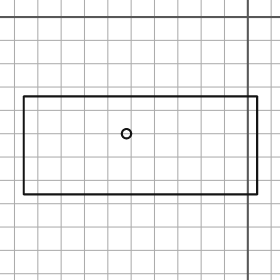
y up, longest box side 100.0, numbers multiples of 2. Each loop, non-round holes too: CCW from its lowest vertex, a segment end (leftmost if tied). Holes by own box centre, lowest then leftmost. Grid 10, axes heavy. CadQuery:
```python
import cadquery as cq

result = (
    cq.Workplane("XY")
    .moveTo(-96.0, -76.0)
    .lineTo(4.0, -76.0)
    .lineTo(4.0, -34.0)
    .lineTo(-96.0, -34.0)
    .close()
    .moveTo(-52.0, -50.0)
    .circle(2.0)
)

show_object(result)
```